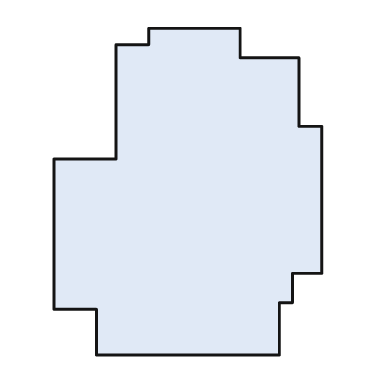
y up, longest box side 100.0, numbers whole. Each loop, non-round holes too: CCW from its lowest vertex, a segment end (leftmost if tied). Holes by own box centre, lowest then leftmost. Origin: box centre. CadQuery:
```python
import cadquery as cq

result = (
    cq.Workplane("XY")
    .moveTo(-28.0, -50.0)
    .lineTo(28.0, -50.0)
    .lineTo(28.0, -34.0)
    .lineTo(32.0, -34.0)
    .lineTo(32.0, -25.0)
    .lineTo(41.0, -25.0)
    .lineTo(41.0, 20.0)
    .lineTo(34.0, 20.0)
    .lineTo(34.0, 41.0)
    .lineTo(16.0, 41.0)
    .lineTo(16.0, 50.0)
    .lineTo(-12.0, 50.0)
    .lineTo(-12.0, 45.0)
    .lineTo(-22.0, 45.0)
    .lineTo(-22.0, 10.0)
    .lineTo(-41.0, 10.0)
    .lineTo(-41.0, -36.0)
    .lineTo(-28.0, -36.0)
    .close()
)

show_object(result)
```